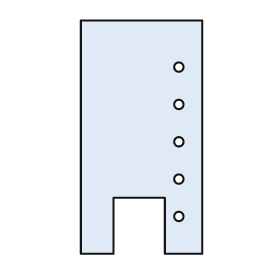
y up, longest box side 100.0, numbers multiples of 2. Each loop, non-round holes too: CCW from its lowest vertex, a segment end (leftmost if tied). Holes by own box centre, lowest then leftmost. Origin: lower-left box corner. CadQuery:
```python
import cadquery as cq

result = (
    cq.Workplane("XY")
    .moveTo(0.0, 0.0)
    .lineTo(14.0, 0.0)
    .lineTo(14.0, 24.0)
    .lineTo(36.0, 24.0)
    .lineTo(36.0, 0.0)
    .lineTo(52.0, 0.0)
    .lineTo(52.0, 100.0)
    .lineTo(0.0, 100.0)
    .close()
    .moveTo(42.0, 16.0)
    .circle(2.0)
    .moveTo(42.0, 32.0)
    .circle(2.0)
    .moveTo(42.0, 48.0)
    .circle(2.0)
    .moveTo(42.0, 64.0)
    .circle(2.0)
    .moveTo(42.0, 80.0)
    .circle(2.0)
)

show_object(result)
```